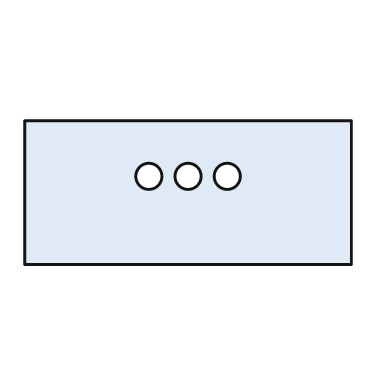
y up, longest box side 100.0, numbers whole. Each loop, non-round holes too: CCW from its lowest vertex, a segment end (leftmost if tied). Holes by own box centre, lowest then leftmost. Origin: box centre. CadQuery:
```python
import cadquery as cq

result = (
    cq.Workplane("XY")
    .moveTo(-50.0, -22.0)
    .lineTo(50.0, -22.0)
    .lineTo(50.0, 22.0)
    .lineTo(-50.0, 22.0)
    .close()
    .moveTo(-12.0, 5.0)
    .circle(4.0)
    .moveTo(0.0, 5.0)
    .circle(4.0)
    .moveTo(12.0, 5.0)
    .circle(4.0)
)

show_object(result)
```